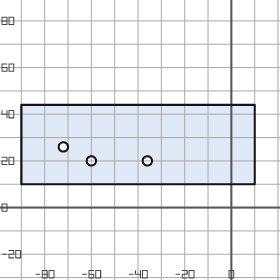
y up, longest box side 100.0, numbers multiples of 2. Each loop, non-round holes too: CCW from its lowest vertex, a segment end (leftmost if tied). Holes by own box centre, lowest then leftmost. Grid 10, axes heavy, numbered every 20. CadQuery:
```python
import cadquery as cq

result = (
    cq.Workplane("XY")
    .moveTo(-90.0, 10.0)
    .lineTo(10.0, 10.0)
    .lineTo(10.0, 44.0)
    .lineTo(-90.0, 44.0)
    .close()
    .moveTo(-60.0, 20.0)
    .circle(2.0)
    .moveTo(-36.0, 20.0)
    .circle(2.0)
    .moveTo(-72.0, 26.0)
    .circle(2.0)
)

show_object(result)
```